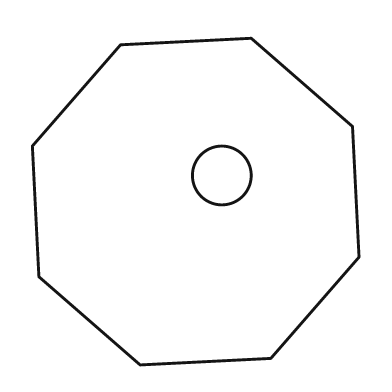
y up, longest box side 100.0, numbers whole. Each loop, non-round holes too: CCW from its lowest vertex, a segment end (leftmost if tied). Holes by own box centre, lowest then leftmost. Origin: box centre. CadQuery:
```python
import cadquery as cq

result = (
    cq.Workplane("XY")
    .moveTo(-17.0, -50.0)
    .lineTo(23.0, -48.0)
    .lineTo(50.0, -17.0)
    .lineTo(48.0, 23.0)
    .lineTo(17.0, 50.0)
    .lineTo(-23.0, 48.0)
    .lineTo(-50.0, 17.0)
    .lineTo(-48.0, -23.0)
    .close()
    .moveTo(8.0, 8.0)
    .circle(9.0)
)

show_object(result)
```